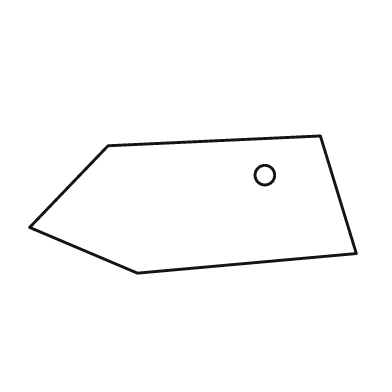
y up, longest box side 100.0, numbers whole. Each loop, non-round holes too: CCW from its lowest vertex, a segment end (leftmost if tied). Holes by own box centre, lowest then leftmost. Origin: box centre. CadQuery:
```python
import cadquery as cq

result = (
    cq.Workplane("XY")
    .moveTo(-17.0, -21.0)
    .lineTo(50.0, -15.0)
    .lineTo(39.0, 21.0)
    .lineTo(-26.0, 18.0)
    .lineTo(-50.0, -7.0)
    .close()
    .moveTo(22.0, 9.0)
    .circle(3.0)
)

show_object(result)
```